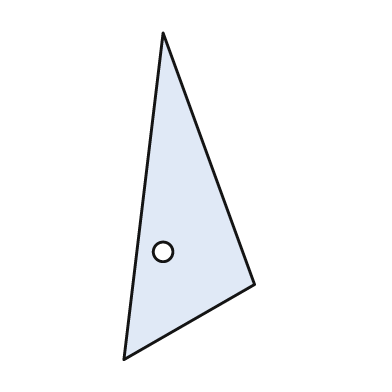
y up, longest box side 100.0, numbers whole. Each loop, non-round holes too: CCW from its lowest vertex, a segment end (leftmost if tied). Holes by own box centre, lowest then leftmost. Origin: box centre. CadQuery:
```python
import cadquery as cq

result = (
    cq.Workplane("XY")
    .moveTo(-20.0, -50.0)
    .lineTo(20.0, -27.0)
    .lineTo(-8.0, 50.0)
    .close()
    .moveTo(-8.0, -17.0)
    .circle(3.0)
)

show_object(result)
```